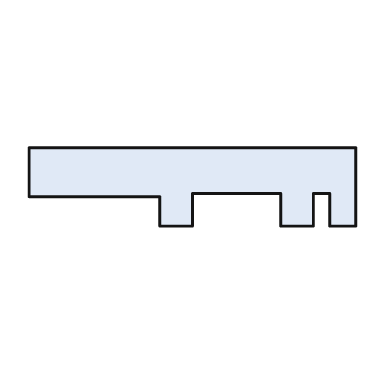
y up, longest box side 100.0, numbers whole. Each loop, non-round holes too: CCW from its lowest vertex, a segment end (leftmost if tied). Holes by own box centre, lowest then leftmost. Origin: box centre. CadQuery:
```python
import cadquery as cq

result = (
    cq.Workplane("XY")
    .moveTo(-10.0, -12.0)
    .lineTo(0.0, -12.0)
    .lineTo(0.0, -2.0)
    .lineTo(27.0, -2.0)
    .lineTo(27.0, -12.0)
    .lineTo(37.0, -12.0)
    .lineTo(37.0, -2.0)
    .lineTo(42.0, -2.0)
    .lineTo(42.0, -12.0)
    .lineTo(50.0, -12.0)
    .lineTo(50.0, 12.0)
    .lineTo(-50.0, 12.0)
    .lineTo(-50.0, -3.0)
    .lineTo(-10.0, -3.0)
    .close()
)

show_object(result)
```